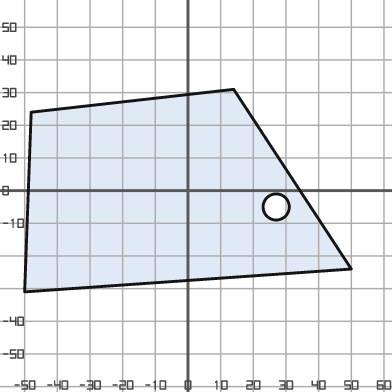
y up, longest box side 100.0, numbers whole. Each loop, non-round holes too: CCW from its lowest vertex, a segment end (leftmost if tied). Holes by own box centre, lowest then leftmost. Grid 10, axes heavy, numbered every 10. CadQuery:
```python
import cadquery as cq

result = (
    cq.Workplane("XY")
    .moveTo(-50.0, -31.0)
    .lineTo(50.0, -24.0)
    .lineTo(14.0, 31.0)
    .lineTo(-48.0, 24.0)
    .close()
    .moveTo(27.0, -5.0)
    .circle(4.0)
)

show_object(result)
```